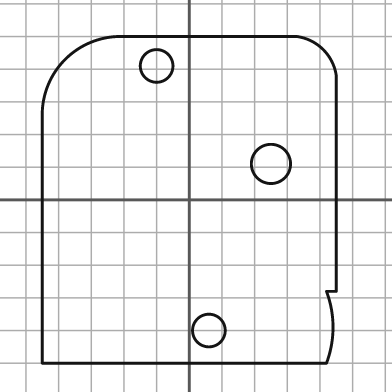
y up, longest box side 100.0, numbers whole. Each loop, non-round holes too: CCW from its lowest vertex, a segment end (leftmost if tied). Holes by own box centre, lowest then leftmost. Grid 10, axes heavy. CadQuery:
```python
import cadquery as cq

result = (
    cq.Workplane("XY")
    .moveTo(-45.0, -50.0)
    .lineTo(42.0, -50.0)
    .threePointArc((44.0, -39.0), (42.0, -28.0))
    .lineTo(45.0, -28.0)
    .lineTo(45.0, 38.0)
    .threePointArc((41.0, 46.0), (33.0, 50.0))
    .lineTo(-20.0, 50.0)
    .threePointArc((-38.0, 43.0), (-45.0, 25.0))
    .close()
    .moveTo(6.0, -40.0)
    .circle(5.0)
    .moveTo(25.0, 11.0)
    .circle(6.0)
    .moveTo(-10.0, 41.0)
    .circle(5.0)
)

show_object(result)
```